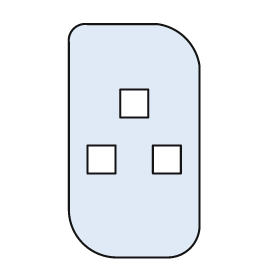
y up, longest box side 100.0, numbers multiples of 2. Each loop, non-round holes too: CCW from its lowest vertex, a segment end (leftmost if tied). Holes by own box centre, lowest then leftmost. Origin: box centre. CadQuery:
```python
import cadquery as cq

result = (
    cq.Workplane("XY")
    .moveTo(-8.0, -50.0)
    .lineTo(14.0, -50.0)
    .threePointArc((24.0, -46.0), (28.0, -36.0))
    .lineTo(28.0, 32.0)
    .threePointArc((22.0, 44.0), (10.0, 50.0))
    .lineTo(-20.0, 50.0)
    .threePointArc((-26.0, 48.0), (-28.0, 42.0))
    .lineTo(-28.0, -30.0)
    .threePointArc((-22.0, -44.0), (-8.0, -50.0))
    .close()
    .moveTo(-20.0, -14.0)
    .lineTo(-8.0, -14.0)
    .lineTo(-8.0, -2.0)
    .lineTo(-20.0, -2.0)
    .close()
    .moveTo(8.0, -14.0)
    .lineTo(20.0, -14.0)
    .lineTo(20.0, -2.0)
    .lineTo(8.0, -2.0)
    .close()
    .moveTo(-6.0, 10.0)
    .lineTo(6.0, 10.0)
    .lineTo(6.0, 22.0)
    .lineTo(-6.0, 22.0)
    .close()
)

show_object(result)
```